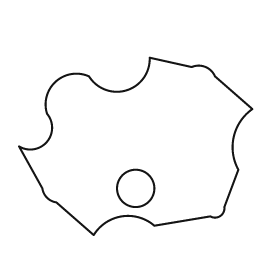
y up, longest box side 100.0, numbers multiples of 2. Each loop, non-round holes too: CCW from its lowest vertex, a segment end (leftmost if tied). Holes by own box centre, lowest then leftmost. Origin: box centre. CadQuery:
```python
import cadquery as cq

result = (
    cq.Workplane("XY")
    .moveTo(-18.0, -38.0)
    .threePointArc((-6.0, -30.0), (8.0, -34.0))
    .lineTo(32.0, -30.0)
    .threePointArc((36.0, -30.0), (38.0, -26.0))
    .lineTo(44.0, -10.0)
    .threePointArc((42.0, 4.0), (50.0, 16.0))
    .lineTo(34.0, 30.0)
    .threePointArc((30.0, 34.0), (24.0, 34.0))
    .lineTo(6.0, 38.0)
    .threePointArc((-4.0, 24.0), (-20.0, 30.0))
    .threePointArc((-34.0, 28.0), (-38.0, 14.0))
    .threePointArc((-38.0, 2.0), (-50.0, 0.0))
    .lineTo(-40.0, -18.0)
    .threePointArc((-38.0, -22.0), (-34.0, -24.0))
    .close()
    .moveTo(0.0, -18.0)
    .circle(8.0)
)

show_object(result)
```